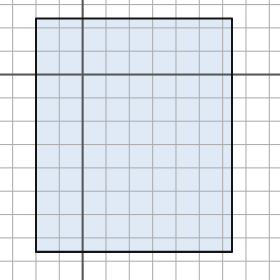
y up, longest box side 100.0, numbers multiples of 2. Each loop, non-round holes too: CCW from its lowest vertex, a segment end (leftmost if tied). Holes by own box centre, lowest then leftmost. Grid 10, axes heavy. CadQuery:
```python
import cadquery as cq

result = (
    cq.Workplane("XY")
    .moveTo(-20.0, -76.0)
    .lineTo(64.0, -76.0)
    .lineTo(64.0, 24.0)
    .lineTo(-20.0, 24.0)
    .close()
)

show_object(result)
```